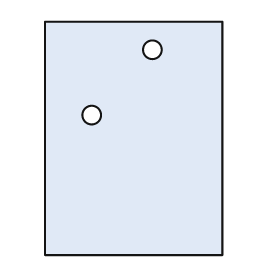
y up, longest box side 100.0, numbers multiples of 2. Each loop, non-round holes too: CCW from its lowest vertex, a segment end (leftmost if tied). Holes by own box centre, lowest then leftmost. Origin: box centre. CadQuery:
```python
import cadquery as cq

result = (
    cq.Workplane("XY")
    .moveTo(-38.0, -50.0)
    .lineTo(38.0, -50.0)
    .lineTo(38.0, 50.0)
    .lineTo(-38.0, 50.0)
    .close()
    .moveTo(-18.0, 10.0)
    .circle(4.0)
    .moveTo(8.0, 38.0)
    .circle(4.0)
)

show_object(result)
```